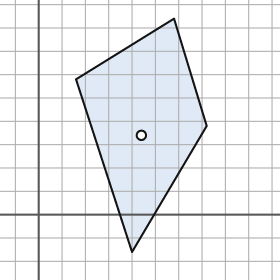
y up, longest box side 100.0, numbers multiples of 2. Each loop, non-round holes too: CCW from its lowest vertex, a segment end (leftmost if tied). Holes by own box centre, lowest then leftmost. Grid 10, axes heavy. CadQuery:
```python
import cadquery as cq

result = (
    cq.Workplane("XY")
    .moveTo(40.0, -16.0)
    .lineTo(72.0, 38.0)
    .lineTo(58.0, 84.0)
    .lineTo(16.0, 58.0)
    .close()
    .moveTo(44.0, 34.0)
    .circle(2.0)
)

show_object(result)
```